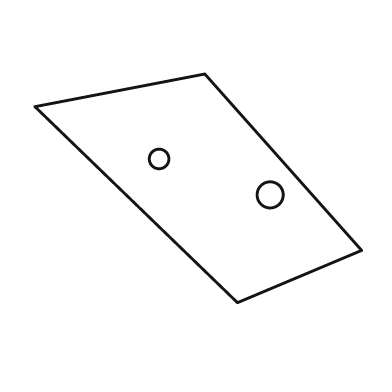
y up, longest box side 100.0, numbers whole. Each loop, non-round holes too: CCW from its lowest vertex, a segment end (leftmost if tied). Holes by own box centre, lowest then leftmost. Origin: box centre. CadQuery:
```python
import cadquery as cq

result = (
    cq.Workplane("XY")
    .moveTo(12.0, -35.0)
    .lineTo(50.0, -19.0)
    .lineTo(2.0, 35.0)
    .lineTo(-50.0, 25.0)
    .close()
    .moveTo(22.0, -2.0)
    .circle(4.0)
    .moveTo(-12.0, 9.0)
    .circle(3.0)
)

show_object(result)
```